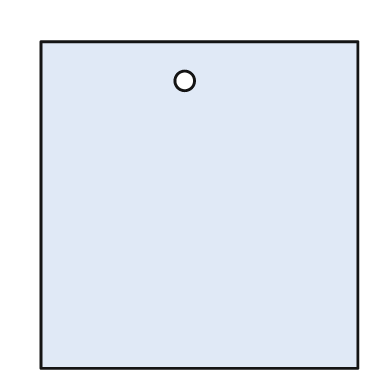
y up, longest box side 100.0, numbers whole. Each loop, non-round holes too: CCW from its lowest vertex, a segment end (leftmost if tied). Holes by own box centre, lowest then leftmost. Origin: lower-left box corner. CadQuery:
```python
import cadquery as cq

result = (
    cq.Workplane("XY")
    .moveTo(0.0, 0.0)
    .lineTo(97.0, 0.0)
    .lineTo(97.0, 100.0)
    .lineTo(0.0, 100.0)
    .close()
    .moveTo(44.0, 88.0)
    .circle(3.0)
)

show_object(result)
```